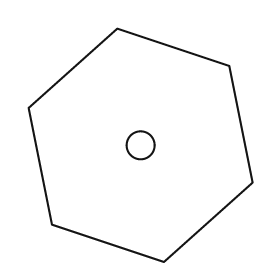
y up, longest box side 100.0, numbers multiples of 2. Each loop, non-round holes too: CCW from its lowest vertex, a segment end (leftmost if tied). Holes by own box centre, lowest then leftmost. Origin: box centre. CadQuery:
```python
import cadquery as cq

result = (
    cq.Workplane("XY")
    .moveTo(10.0, -50.0)
    .lineTo(48.0, -16.0)
    .lineTo(38.0, 34.0)
    .lineTo(-10.0, 50.0)
    .lineTo(-48.0, 16.0)
    .lineTo(-38.0, -34.0)
    .close()
    .moveTo(0.0, 0.0)
    .circle(6.0)
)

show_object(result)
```